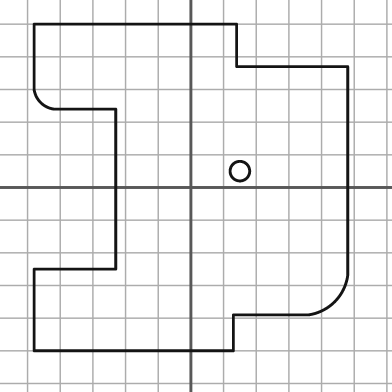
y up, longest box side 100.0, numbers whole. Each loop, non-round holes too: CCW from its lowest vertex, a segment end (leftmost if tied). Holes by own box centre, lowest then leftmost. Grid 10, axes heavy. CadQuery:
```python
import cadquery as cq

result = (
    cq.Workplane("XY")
    .moveTo(-48.0, -50.0)
    .lineTo(13.0, -50.0)
    .lineTo(13.0, -39.0)
    .lineTo(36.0, -39.0)
    .threePointArc((44.0, -35.0), (48.0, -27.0))
    .lineTo(48.0, 37.0)
    .lineTo(14.0, 37.0)
    .lineTo(14.0, 50.0)
    .lineTo(-48.0, 50.0)
    .lineTo(-48.0, 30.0)
    .threePointArc((-46.0, 26.0), (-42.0, 24.0))
    .lineTo(-23.0, 24.0)
    .lineTo(-23.0, -25.0)
    .lineTo(-48.0, -25.0)
    .close()
    .moveTo(15.0, 5.0)
    .circle(3.0)
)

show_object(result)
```